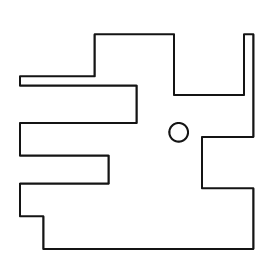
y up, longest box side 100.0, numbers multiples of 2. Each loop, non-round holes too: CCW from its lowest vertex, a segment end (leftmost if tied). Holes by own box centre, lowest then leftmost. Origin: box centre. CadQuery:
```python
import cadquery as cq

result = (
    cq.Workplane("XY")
    .moveTo(-40.0, -46.0)
    .lineTo(50.0, -46.0)
    .lineTo(50.0, -20.0)
    .lineTo(28.0, -20.0)
    .lineTo(28.0, 2.0)
    .lineTo(50.0, 2.0)
    .lineTo(50.0, 46.0)
    .lineTo(46.0, 46.0)
    .lineTo(46.0, 20.0)
    .lineTo(16.0, 20.0)
    .lineTo(16.0, 46.0)
    .lineTo(-18.0, 46.0)
    .lineTo(-18.0, 28.0)
    .lineTo(-50.0, 28.0)
    .lineTo(-50.0, 24.0)
    .lineTo(0.0, 24.0)
    .lineTo(0.0, 8.0)
    .lineTo(-50.0, 8.0)
    .lineTo(-50.0, -6.0)
    .lineTo(-12.0, -6.0)
    .lineTo(-12.0, -18.0)
    .lineTo(-50.0, -18.0)
    .lineTo(-50.0, -32.0)
    .lineTo(-40.0, -32.0)
    .close()
    .moveTo(18.0, 4.0)
    .circle(4.0)
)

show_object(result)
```